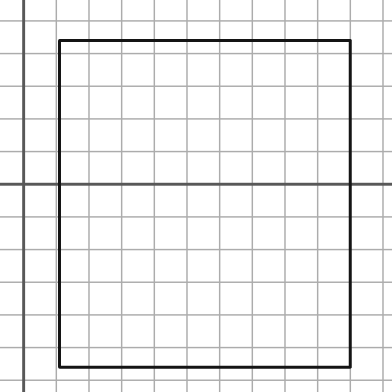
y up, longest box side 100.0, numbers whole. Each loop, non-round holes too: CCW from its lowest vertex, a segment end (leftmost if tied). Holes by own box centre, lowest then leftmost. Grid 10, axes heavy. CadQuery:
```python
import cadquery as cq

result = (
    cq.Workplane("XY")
    .moveTo(11.0, -56.0)
    .lineTo(100.0, -56.0)
    .lineTo(100.0, 44.0)
    .lineTo(11.0, 44.0)
    .close()
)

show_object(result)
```